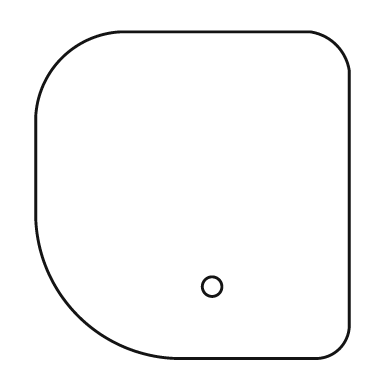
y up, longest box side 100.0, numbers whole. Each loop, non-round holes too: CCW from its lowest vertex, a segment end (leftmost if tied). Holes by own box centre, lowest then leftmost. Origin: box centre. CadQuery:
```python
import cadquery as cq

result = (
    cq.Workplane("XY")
    .moveTo(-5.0, -50.0)
    .lineTo(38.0, -50.0)
    .threePointArc((45.0, -47.0), (48.0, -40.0))
    .lineTo(48.0, 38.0)
    .threePointArc((44.0, 46.0), (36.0, 50.0))
    .lineTo(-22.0, 50.0)
    .threePointArc((-40.0, 42.0), (-48.0, 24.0))
    .lineTo(-48.0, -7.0)
    .threePointArc((-35.0, -37.0), (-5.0, -50.0))
    .close()
    .moveTo(6.0, -28.0)
    .circle(3.0)
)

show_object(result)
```